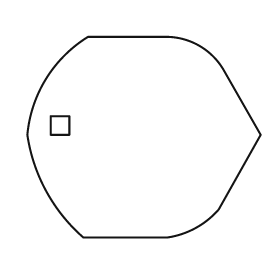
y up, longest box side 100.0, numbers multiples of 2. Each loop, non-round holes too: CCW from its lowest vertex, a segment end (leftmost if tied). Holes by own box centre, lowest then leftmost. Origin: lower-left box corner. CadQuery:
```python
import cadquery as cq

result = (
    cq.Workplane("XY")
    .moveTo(24.0, 0.0)
    .lineTo(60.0, 0.0)
    .threePointArc((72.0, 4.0), (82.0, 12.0))
    .lineTo(100.0, 44.0)
    .lineTo(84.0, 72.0)
    .threePointArc((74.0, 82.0), (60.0, 86.0))
    .lineTo(26.0, 86.0)
    .threePointArc((8.0, 68.0), (0.0, 44.0))
    .threePointArc((8.0, 20.0), (24.0, 0.0))
    .close()
    .moveTo(10.0, 44.0)
    .lineTo(18.0, 44.0)
    .lineTo(18.0, 52.0)
    .lineTo(10.0, 52.0)
    .close()
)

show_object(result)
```